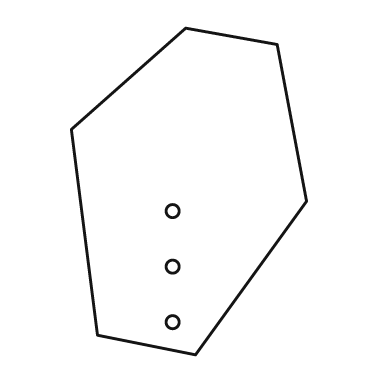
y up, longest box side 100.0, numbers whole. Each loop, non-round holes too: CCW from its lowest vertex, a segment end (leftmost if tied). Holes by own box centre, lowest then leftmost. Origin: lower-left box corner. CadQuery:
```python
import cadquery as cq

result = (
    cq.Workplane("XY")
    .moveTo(38.0, 0.0)
    .lineTo(72.0, 47.0)
    .lineTo(63.0, 95.0)
    .lineTo(35.0, 100.0)
    .lineTo(0.0, 69.0)
    .lineTo(8.0, 6.0)
    .close()
    .moveTo(31.0, 10.0)
    .circle(2.0)
    .moveTo(31.0, 27.0)
    .circle(2.0)
    .moveTo(31.0, 44.0)
    .circle(2.0)
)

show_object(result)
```